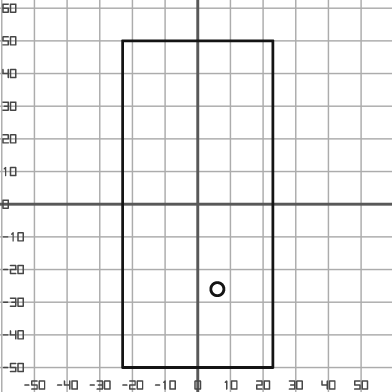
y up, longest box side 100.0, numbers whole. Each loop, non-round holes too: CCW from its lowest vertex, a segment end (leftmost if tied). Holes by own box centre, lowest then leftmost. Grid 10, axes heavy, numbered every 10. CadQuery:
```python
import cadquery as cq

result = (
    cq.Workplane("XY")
    .moveTo(-23.0, -50.0)
    .lineTo(23.0, -50.0)
    .lineTo(23.0, 50.0)
    .lineTo(-23.0, 50.0)
    .close()
    .moveTo(6.0, -26.0)
    .circle(2.0)
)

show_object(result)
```